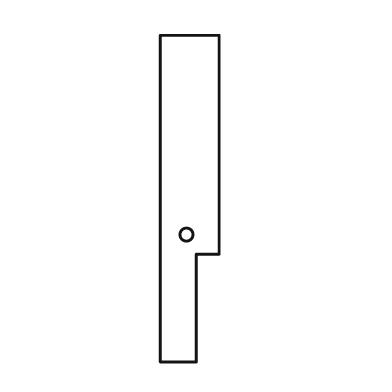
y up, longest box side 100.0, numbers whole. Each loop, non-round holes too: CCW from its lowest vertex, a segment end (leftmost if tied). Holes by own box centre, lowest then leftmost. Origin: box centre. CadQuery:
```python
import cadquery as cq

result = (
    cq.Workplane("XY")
    .moveTo(-9.0, -50.0)
    .lineTo(2.0, -50.0)
    .lineTo(2.0, -17.0)
    .lineTo(9.0, -17.0)
    .lineTo(9.0, 50.0)
    .lineTo(-9.0, 50.0)
    .close()
    .moveTo(-1.0, -11.0)
    .circle(2.0)
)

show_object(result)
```